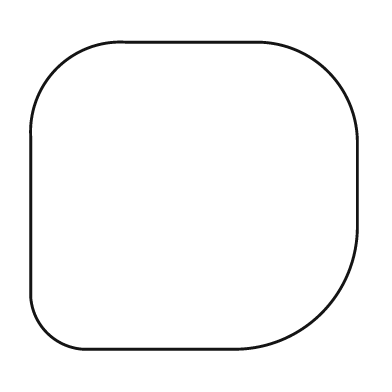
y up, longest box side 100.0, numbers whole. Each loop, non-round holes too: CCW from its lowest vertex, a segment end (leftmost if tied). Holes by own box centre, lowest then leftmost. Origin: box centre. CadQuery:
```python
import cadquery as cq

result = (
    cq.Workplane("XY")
    .moveTo(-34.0, -47.0)
    .lineTo(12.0, -47.0)
    .threePointArc((39.0, -36.0), (50.0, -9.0))
    .lineTo(50.0, 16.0)
    .threePointArc((41.0, 38.0), (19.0, 47.0))
    .lineTo(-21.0, 47.0)
    .threePointArc((-42.0, 39.0), (-50.0, 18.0))
    .lineTo(-50.0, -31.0)
    .threePointArc((-45.0, -42.0), (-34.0, -47.0))
    .close()
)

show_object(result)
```